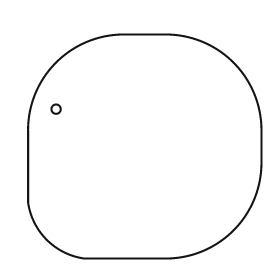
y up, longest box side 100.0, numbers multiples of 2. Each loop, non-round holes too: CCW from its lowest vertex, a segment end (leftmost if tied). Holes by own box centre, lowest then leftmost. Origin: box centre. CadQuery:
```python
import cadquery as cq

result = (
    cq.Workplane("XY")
    .moveTo(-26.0, -48.0)
    .lineTo(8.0, -48.0)
    .threePointArc((38.0, -36.0), (50.0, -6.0))
    .lineTo(50.0, 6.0)
    .threePointArc((38.0, 36.0), (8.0, 48.0))
    .lineTo(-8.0, 48.0)
    .threePointArc((-38.0, 36.0), (-50.0, 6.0))
    .lineTo(-50.0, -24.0)
    .threePointArc((-42.0, -40.0), (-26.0, -48.0))
    .close()
    .moveTo(-38.0, 16.0)
    .circle(2.0)
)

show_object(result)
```